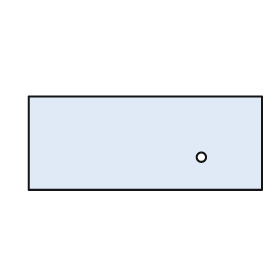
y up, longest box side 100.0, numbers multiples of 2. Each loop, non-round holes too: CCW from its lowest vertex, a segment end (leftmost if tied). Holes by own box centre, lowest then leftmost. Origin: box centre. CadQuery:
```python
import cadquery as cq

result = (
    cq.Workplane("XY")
    .moveTo(-50.0, -20.0)
    .lineTo(50.0, -20.0)
    .lineTo(50.0, 20.0)
    .lineTo(-50.0, 20.0)
    .close()
    .moveTo(24.0, -6.0)
    .circle(2.0)
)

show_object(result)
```